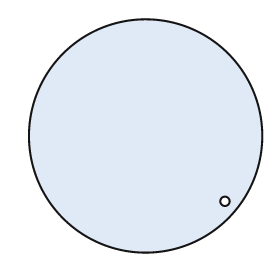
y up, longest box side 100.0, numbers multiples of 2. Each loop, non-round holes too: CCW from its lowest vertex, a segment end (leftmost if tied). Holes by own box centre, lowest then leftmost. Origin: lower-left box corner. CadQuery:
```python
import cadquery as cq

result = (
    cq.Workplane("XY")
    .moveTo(50.0, 50.0)
    .circle(50.0)
    .moveTo(84.0, 22.0)
    .circle(2.0)
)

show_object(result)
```